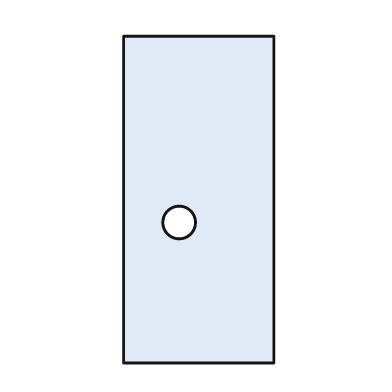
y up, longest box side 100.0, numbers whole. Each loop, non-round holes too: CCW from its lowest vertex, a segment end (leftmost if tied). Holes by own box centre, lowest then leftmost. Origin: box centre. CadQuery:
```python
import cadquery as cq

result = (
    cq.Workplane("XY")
    .moveTo(-23.0, -50.0)
    .lineTo(23.0, -50.0)
    .lineTo(23.0, 50.0)
    .lineTo(-23.0, 50.0)
    .close()
    .moveTo(-6.0, -7.0)
    .circle(5.0)
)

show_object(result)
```